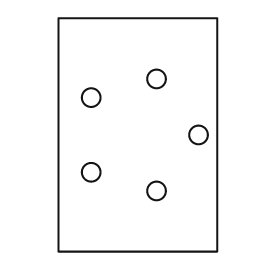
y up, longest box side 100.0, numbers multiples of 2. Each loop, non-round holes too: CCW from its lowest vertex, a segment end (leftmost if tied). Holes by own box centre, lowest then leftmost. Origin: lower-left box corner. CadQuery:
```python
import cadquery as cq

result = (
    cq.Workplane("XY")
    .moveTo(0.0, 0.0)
    .lineTo(68.0, 0.0)
    .lineTo(68.0, 100.0)
    .lineTo(0.0, 100.0)
    .close()
    .moveTo(42.0, 26.0)
    .circle(4.0)
    .moveTo(14.0, 34.0)
    .circle(4.0)
    .moveTo(60.0, 50.0)
    .circle(4.0)
    .moveTo(14.0, 66.0)
    .circle(4.0)
    .moveTo(42.0, 74.0)
    .circle(4.0)
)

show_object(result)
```